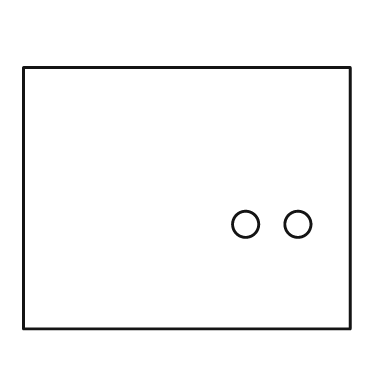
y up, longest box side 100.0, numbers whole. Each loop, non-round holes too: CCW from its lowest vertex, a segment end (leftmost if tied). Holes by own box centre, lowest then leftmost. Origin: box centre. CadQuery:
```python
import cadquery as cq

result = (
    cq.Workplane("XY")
    .moveTo(-50.0, -40.0)
    .lineTo(50.0, -40.0)
    .lineTo(50.0, 40.0)
    .lineTo(-50.0, 40.0)
    .close()
    .moveTo(18.0, -8.0)
    .circle(4.0)
    .moveTo(34.0, -8.0)
    .circle(4.0)
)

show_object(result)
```